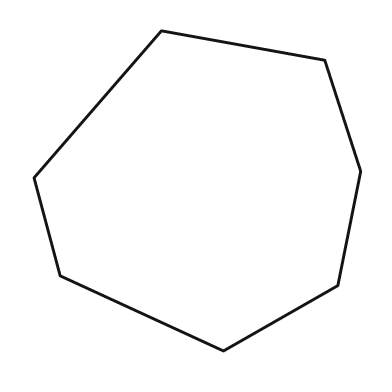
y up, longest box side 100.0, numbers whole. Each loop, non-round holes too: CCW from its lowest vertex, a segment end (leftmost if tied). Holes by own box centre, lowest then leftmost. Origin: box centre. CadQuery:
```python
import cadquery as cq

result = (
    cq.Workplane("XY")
    .moveTo(8.0, -49.0)
    .lineTo(43.0, -29.0)
    .lineTo(50.0, 6.0)
    .lineTo(39.0, 40.0)
    .lineTo(-11.0, 49.0)
    .lineTo(-50.0, 4.0)
    .lineTo(-42.0, -26.0)
    .close()
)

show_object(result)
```